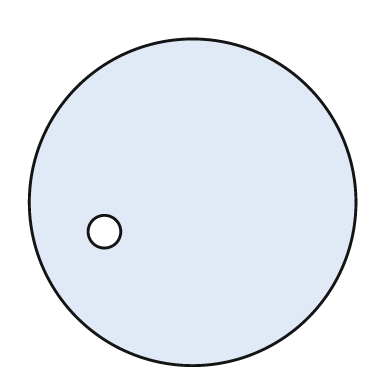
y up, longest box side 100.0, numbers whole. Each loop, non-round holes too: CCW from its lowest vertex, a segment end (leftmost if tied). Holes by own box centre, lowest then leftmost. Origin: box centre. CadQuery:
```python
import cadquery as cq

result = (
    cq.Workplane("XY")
    .moveTo(0.0, 0.0)
    .circle(50.0)
    .moveTo(-27.0, -9.0)
    .circle(5.0)
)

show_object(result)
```